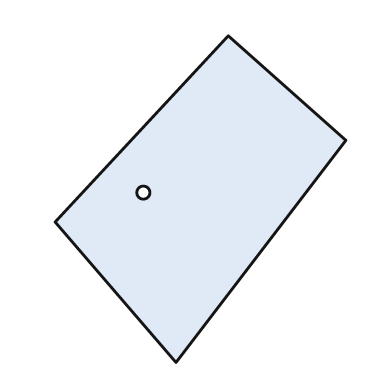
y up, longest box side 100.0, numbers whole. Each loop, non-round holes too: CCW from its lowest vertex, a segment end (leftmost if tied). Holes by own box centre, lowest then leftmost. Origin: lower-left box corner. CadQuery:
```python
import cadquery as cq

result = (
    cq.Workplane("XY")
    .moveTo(37.0, 0.0)
    .lineTo(89.0, 68.0)
    .lineTo(53.0, 100.0)
    .lineTo(0.0, 43.0)
    .close()
    .moveTo(27.0, 52.0)
    .circle(2.0)
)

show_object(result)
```